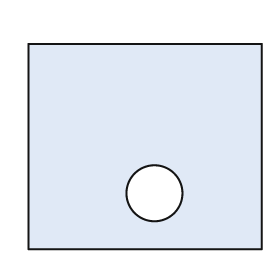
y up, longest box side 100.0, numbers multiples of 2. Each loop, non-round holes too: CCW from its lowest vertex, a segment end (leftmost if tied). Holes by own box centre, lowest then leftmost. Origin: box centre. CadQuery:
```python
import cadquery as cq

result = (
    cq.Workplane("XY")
    .moveTo(-50.0, -44.0)
    .lineTo(50.0, -44.0)
    .lineTo(50.0, 44.0)
    .lineTo(-50.0, 44.0)
    .close()
    .moveTo(4.0, -20.0)
    .circle(12.0)
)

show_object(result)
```